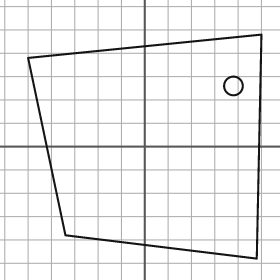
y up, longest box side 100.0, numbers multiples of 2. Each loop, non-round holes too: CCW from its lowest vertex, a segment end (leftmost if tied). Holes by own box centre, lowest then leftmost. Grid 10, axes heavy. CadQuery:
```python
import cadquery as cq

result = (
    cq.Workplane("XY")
    .moveTo(48.0, -48.0)
    .lineTo(50.0, 48.0)
    .lineTo(-50.0, 38.0)
    .lineTo(-34.0, -38.0)
    .close()
    .moveTo(38.0, 26.0)
    .circle(4.0)
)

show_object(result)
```